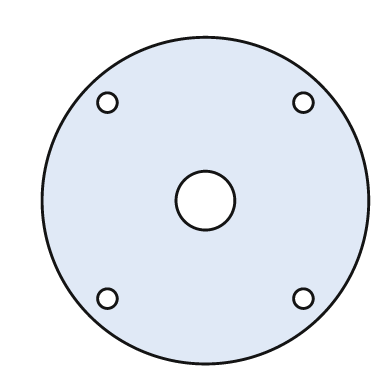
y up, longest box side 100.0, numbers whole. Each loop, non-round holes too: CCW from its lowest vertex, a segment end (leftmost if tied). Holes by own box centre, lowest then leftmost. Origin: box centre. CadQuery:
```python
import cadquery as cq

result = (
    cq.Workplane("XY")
    .moveTo(0.0, 0.0)
    .circle(50.0)
    .moveTo(-30.0, -30.0)
    .circle(3.0)
    .moveTo(30.0, -30.0)
    .circle(3.0)
    .moveTo(0.0, 0.0)
    .circle(9.0)
    .moveTo(-30.0, 30.0)
    .circle(3.0)
    .moveTo(30.0, 30.0)
    .circle(3.0)
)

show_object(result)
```